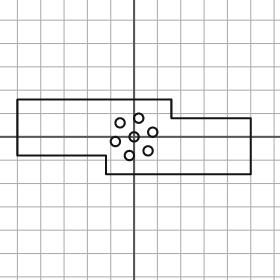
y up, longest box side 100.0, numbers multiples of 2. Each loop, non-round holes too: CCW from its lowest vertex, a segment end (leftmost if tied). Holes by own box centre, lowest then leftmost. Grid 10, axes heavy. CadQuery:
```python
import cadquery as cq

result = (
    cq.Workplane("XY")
    .moveTo(-12.0, -16.0)
    .lineTo(50.0, -16.0)
    .lineTo(50.0, 8.0)
    .lineTo(16.0, 8.0)
    .lineTo(16.0, 16.0)
    .lineTo(-50.0, 16.0)
    .lineTo(-50.0, -8.0)
    .lineTo(-12.0, -8.0)
    .close()
    .moveTo(-2.0, -8.0)
    .circle(2.0)
    .moveTo(6.0, -6.0)
    .circle(2.0)
    .moveTo(-8.0, -2.0)
    .circle(2.0)
    .moveTo(0.0, 0.0)
    .circle(2.0)
    .moveTo(8.0, 2.0)
    .circle(2.0)
    .moveTo(-6.0, 6.0)
    .circle(2.0)
    .moveTo(2.0, 8.0)
    .circle(2.0)
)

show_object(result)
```